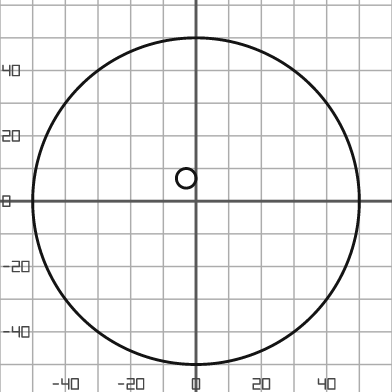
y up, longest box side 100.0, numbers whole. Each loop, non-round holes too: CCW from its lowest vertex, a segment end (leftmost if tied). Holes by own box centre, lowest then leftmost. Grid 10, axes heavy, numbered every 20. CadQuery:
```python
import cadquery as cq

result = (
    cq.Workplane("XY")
    .moveTo(0.0, 0.0)
    .circle(50.0)
    .moveTo(-3.0, 7.0)
    .circle(3.0)
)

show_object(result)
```